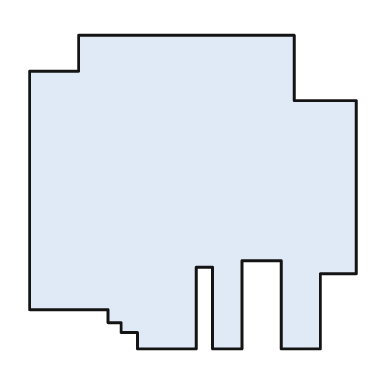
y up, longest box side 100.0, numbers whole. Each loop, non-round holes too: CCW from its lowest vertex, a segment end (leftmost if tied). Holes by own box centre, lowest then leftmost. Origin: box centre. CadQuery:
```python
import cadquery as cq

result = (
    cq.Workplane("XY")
    .moveTo(-17.0, -48.0)
    .lineTo(1.0, -48.0)
    .lineTo(1.0, -23.0)
    .lineTo(6.0, -23.0)
    .lineTo(6.0, -48.0)
    .lineTo(15.0, -48.0)
    .lineTo(15.0, -21.0)
    .lineTo(27.0, -21.0)
    .lineTo(27.0, -48.0)
    .lineTo(39.0, -48.0)
    .lineTo(39.0, -25.0)
    .lineTo(50.0, -25.0)
    .lineTo(50.0, 28.0)
    .lineTo(31.0, 28.0)
    .lineTo(31.0, 48.0)
    .lineTo(-35.0, 48.0)
    .lineTo(-35.0, 37.0)
    .lineTo(-50.0, 37.0)
    .lineTo(-50.0, -36.0)
    .lineTo(-26.0, -36.0)
    .lineTo(-26.0, -40.0)
    .lineTo(-22.0, -40.0)
    .lineTo(-22.0, -43.0)
    .lineTo(-17.0, -43.0)
    .close()
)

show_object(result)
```